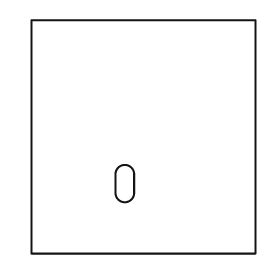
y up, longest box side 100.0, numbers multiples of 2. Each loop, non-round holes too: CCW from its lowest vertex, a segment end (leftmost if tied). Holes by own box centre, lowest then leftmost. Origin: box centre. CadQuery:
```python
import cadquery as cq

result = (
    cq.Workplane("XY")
    .moveTo(-48.0, -50.0)
    .lineTo(48.0, -50.0)
    .lineTo(48.0, 50.0)
    .lineTo(-48.0, 50.0)
    .close()
    .moveTo(-12.0, -24.0)
    .threePointArc((-8.0, -28.0), (-4.0, -24.0))
    .lineTo(-4.0, -16.0)
    .threePointArc((-8.0, -12.0), (-12.0, -16.0))
    .close()
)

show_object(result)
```